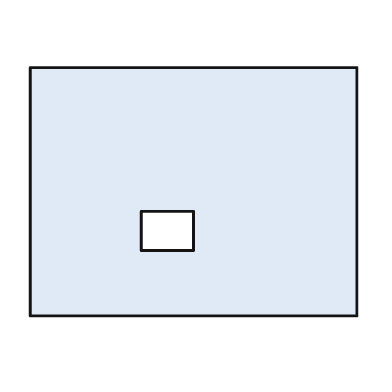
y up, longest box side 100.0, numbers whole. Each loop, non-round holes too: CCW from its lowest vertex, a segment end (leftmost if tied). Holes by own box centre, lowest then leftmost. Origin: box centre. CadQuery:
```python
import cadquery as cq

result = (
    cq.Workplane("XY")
    .moveTo(-50.0, -38.0)
    .lineTo(50.0, -38.0)
    .lineTo(50.0, 38.0)
    .lineTo(-50.0, 38.0)
    .close()
    .moveTo(-16.0, -18.0)
    .lineTo(0.0, -18.0)
    .lineTo(0.0, -6.0)
    .lineTo(-16.0, -6.0)
    .close()
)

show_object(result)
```